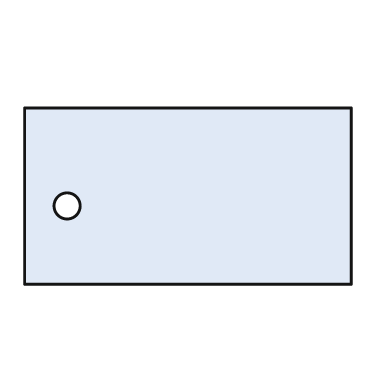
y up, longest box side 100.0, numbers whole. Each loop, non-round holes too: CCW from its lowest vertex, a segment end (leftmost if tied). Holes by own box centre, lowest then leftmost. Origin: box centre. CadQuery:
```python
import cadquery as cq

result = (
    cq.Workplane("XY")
    .moveTo(-50.0, -27.0)
    .lineTo(50.0, -27.0)
    .lineTo(50.0, 27.0)
    .lineTo(-50.0, 27.0)
    .close()
    .moveTo(-37.0, -3.0)
    .circle(4.0)
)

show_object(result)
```